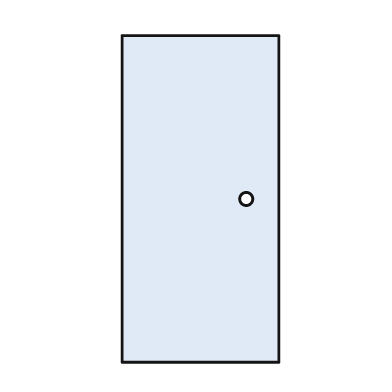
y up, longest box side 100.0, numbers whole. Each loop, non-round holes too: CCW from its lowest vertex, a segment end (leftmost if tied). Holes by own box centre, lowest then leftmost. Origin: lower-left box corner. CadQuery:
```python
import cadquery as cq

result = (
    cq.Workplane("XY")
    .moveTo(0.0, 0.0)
    .lineTo(48.0, 0.0)
    .lineTo(48.0, 100.0)
    .lineTo(0.0, 100.0)
    .close()
    .moveTo(38.0, 50.0)
    .circle(2.0)
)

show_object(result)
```